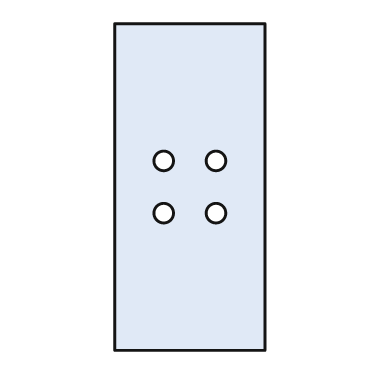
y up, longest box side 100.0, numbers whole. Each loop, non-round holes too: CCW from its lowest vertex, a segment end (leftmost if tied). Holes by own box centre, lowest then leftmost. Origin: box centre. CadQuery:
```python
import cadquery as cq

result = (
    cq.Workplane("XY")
    .moveTo(-23.0, -50.0)
    .lineTo(23.0, -50.0)
    .lineTo(23.0, 50.0)
    .lineTo(-23.0, 50.0)
    .close()
    .moveTo(-8.0, -8.0)
    .circle(3.0)
    .moveTo(8.0, -8.0)
    .circle(3.0)
    .moveTo(-8.0, 8.0)
    .circle(3.0)
    .moveTo(8.0, 8.0)
    .circle(3.0)
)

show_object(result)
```